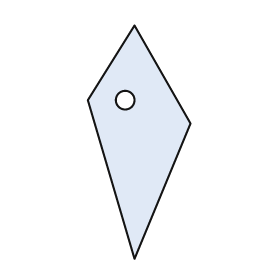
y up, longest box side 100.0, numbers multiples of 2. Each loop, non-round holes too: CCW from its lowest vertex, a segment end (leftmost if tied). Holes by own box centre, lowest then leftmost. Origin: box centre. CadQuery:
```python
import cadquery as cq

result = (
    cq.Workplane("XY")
    .moveTo(-2.0, -50.0)
    .lineTo(22.0, 8.0)
    .lineTo(-2.0, 50.0)
    .lineTo(-22.0, 18.0)
    .close()
    .moveTo(-6.0, 18.0)
    .circle(4.0)
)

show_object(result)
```